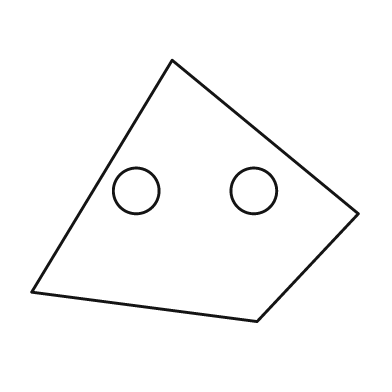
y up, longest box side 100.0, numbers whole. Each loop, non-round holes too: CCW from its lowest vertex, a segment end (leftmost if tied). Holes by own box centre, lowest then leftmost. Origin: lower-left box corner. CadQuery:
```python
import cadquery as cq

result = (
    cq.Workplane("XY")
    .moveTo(69.0, 0.0)
    .lineTo(100.0, 33.0)
    .lineTo(43.0, 80.0)
    .lineTo(0.0, 9.0)
    .close()
    .moveTo(32.0, 40.0)
    .circle(7.0)
    .moveTo(68.0, 40.0)
    .circle(7.0)
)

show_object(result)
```